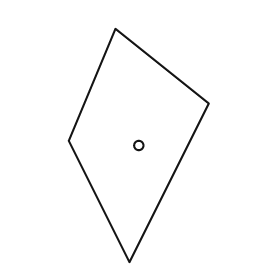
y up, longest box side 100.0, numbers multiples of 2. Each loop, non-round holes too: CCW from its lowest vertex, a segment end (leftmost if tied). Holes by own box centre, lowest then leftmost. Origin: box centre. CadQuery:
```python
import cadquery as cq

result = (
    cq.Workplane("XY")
    .moveTo(-4.0, -50.0)
    .lineTo(30.0, 18.0)
    .lineTo(-10.0, 50.0)
    .lineTo(-30.0, 2.0)
    .close()
    .moveTo(0.0, 0.0)
    .circle(2.0)
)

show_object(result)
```